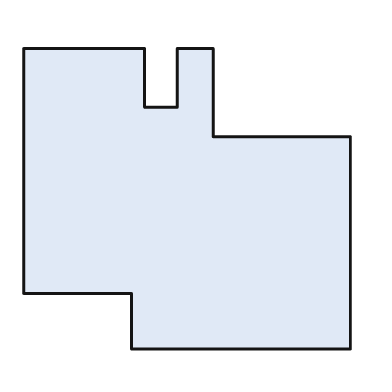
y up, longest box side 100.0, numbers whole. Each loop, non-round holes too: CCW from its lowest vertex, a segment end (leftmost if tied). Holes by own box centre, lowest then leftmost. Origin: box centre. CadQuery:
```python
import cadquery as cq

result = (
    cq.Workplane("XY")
    .moveTo(-17.0, -46.0)
    .lineTo(50.0, -46.0)
    .lineTo(50.0, 19.0)
    .lineTo(8.0, 19.0)
    .lineTo(8.0, 46.0)
    .lineTo(-3.0, 46.0)
    .lineTo(-3.0, 28.0)
    .lineTo(-13.0, 28.0)
    .lineTo(-13.0, 46.0)
    .lineTo(-50.0, 46.0)
    .lineTo(-50.0, -29.0)
    .lineTo(-17.0, -29.0)
    .close()
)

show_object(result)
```